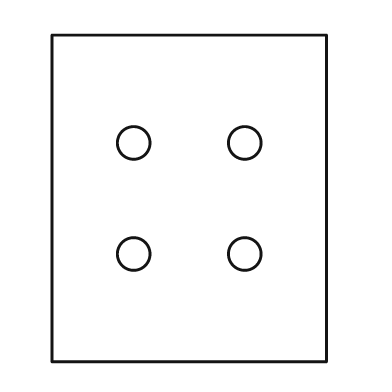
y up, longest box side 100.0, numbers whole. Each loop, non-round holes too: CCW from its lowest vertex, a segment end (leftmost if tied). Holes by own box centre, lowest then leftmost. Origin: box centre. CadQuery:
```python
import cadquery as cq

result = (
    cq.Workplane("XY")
    .moveTo(-42.0, -50.0)
    .lineTo(42.0, -50.0)
    .lineTo(42.0, 50.0)
    .lineTo(-42.0, 50.0)
    .close()
    .moveTo(-17.0, -17.0)
    .circle(5.0)
    .moveTo(17.0, -17.0)
    .circle(5.0)
    .moveTo(-17.0, 17.0)
    .circle(5.0)
    .moveTo(17.0, 17.0)
    .circle(5.0)
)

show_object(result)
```